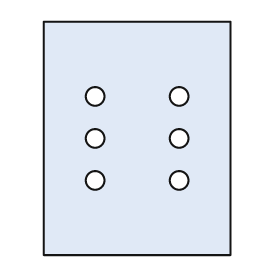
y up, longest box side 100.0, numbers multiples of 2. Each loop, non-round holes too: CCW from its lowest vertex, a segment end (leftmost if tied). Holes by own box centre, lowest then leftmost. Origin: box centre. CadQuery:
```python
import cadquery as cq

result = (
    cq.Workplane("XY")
    .moveTo(-40.0, -50.0)
    .lineTo(40.0, -50.0)
    .lineTo(40.0, 50.0)
    .lineTo(-40.0, 50.0)
    .close()
    .moveTo(-18.0, -18.0)
    .circle(4.0)
    .moveTo(18.0, -18.0)
    .circle(4.0)
    .moveTo(-18.0, 0.0)
    .circle(4.0)
    .moveTo(18.0, 0.0)
    .circle(4.0)
    .moveTo(-18.0, 18.0)
    .circle(4.0)
    .moveTo(18.0, 18.0)
    .circle(4.0)
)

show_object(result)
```